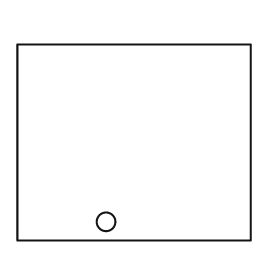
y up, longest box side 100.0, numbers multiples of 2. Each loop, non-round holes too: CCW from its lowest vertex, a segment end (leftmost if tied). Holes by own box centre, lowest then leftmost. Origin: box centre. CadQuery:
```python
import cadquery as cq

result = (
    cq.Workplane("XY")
    .moveTo(-50.0, -42.0)
    .lineTo(50.0, -42.0)
    .lineTo(50.0, 42.0)
    .lineTo(-50.0, 42.0)
    .close()
    .moveTo(-12.0, -34.0)
    .circle(4.0)
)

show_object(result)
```